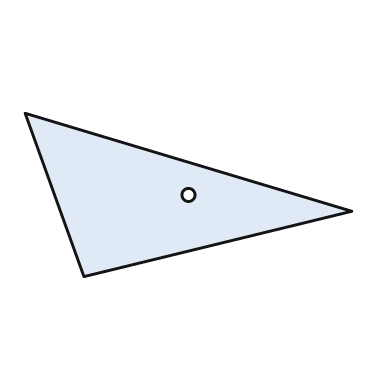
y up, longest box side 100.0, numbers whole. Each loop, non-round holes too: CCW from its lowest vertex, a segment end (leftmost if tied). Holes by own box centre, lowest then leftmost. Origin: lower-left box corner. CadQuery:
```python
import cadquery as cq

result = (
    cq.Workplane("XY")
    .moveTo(18.0, 0.0)
    .lineTo(100.0, 20.0)
    .lineTo(0.0, 50.0)
    .close()
    .moveTo(50.0, 25.0)
    .circle(2.0)
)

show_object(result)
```